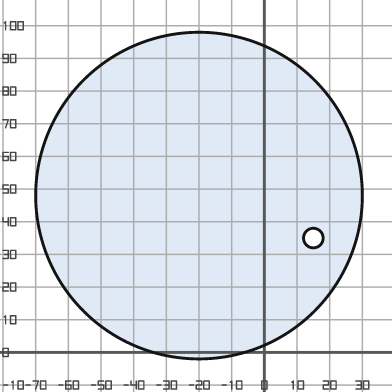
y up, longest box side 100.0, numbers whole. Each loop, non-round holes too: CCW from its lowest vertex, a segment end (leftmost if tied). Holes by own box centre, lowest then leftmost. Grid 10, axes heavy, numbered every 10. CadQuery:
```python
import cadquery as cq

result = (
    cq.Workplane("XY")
    .moveTo(-20.0, 48.0)
    .circle(50.0)
    .moveTo(15.0, 35.0)
    .circle(3.0)
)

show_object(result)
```